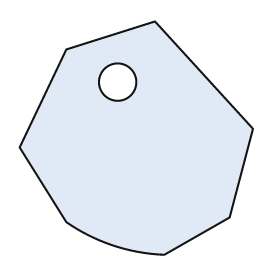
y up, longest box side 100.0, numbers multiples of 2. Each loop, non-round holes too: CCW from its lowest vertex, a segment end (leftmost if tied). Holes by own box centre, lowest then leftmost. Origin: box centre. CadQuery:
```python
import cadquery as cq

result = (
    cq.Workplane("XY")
    .moveTo(12.0, -50.0)
    .lineTo(40.0, -34.0)
    .lineTo(50.0, 4.0)
    .lineTo(8.0, 50.0)
    .lineTo(-30.0, 38.0)
    .lineTo(-50.0, -4.0)
    .lineTo(-30.0, -36.0)
    .threePointArc((-10.0, -46.0), (12.0, -50.0))
    .close()
    .moveTo(-8.0, 24.0)
    .circle(8.0)
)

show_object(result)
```